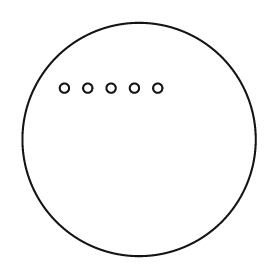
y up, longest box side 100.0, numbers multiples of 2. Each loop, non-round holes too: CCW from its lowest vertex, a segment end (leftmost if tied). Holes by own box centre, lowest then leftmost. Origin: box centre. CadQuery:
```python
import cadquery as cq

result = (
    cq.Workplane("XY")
    .moveTo(0.0, 0.0)
    .circle(50.0)
    .moveTo(-32.0, 22.0)
    .circle(2.0)
    .moveTo(-22.0, 22.0)
    .circle(2.0)
    .moveTo(-12.0, 22.0)
    .circle(2.0)
    .moveTo(-2.0, 22.0)
    .circle(2.0)
    .moveTo(8.0, 22.0)
    .circle(2.0)
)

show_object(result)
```